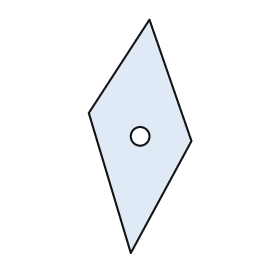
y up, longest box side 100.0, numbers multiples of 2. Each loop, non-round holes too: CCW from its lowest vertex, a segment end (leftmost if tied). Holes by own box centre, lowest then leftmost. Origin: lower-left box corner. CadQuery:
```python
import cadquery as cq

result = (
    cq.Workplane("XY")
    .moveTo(18.0, 0.0)
    .lineTo(44.0, 48.0)
    .lineTo(26.0, 100.0)
    .lineTo(0.0, 60.0)
    .close()
    .moveTo(22.0, 50.0)
    .circle(4.0)
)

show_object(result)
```